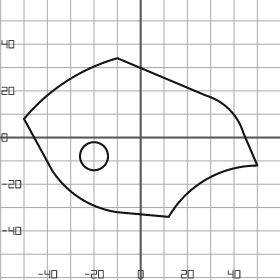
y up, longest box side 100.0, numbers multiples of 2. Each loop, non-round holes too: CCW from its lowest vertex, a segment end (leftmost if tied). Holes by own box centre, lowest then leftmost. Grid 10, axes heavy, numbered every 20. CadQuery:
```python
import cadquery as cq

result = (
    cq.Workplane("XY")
    .moveTo(12.0, -34.0)
    .threePointArc((28.0, -18.0), (50.0, -12.0))
    .lineTo(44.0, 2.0)
    .threePointArc((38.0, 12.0), (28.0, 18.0))
    .lineTo(-10.0, 34.0)
    .threePointArc((-32.0, 24.0), (-50.0, 8.0))
    .lineTo(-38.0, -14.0)
    .threePointArc((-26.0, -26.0), (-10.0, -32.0))
    .close()
    .moveTo(-20.0, -8.0)
    .circle(6.0)
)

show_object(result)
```